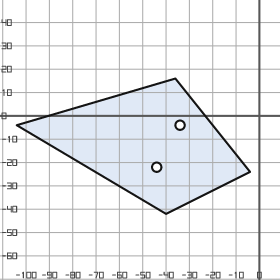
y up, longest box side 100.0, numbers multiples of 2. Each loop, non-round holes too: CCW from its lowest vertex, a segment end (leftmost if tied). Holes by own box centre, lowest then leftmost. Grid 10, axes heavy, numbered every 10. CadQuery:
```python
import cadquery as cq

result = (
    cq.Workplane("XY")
    .moveTo(-40.0, -42.0)
    .lineTo(-4.0, -24.0)
    .lineTo(-36.0, 16.0)
    .lineTo(-104.0, -4.0)
    .close()
    .moveTo(-44.0, -22.0)
    .circle(2.0)
    .moveTo(-34.0, -4.0)
    .circle(2.0)
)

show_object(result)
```